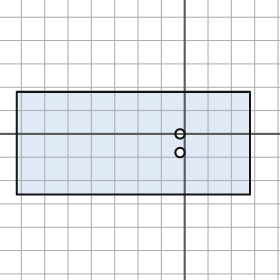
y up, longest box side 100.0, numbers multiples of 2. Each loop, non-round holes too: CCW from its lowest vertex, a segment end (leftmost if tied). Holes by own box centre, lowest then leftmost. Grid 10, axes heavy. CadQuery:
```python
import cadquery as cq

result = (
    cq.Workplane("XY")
    .moveTo(-72.0, -26.0)
    .lineTo(28.0, -26.0)
    .lineTo(28.0, 18.0)
    .lineTo(-72.0, 18.0)
    .close()
    .moveTo(-2.0, -8.0)
    .circle(2.0)
    .moveTo(-2.0, 0.0)
    .circle(2.0)
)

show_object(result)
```